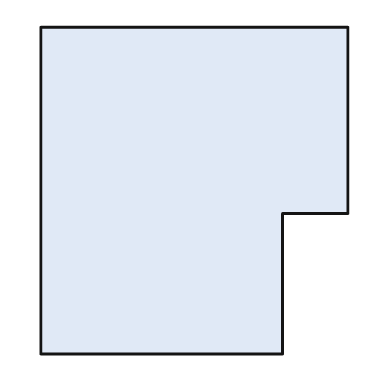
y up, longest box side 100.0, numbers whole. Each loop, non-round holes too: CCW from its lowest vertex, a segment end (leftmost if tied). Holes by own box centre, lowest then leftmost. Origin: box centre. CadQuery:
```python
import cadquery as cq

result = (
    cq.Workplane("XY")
    .moveTo(-47.0, -50.0)
    .lineTo(27.0, -50.0)
    .lineTo(27.0, -7.0)
    .lineTo(47.0, -7.0)
    .lineTo(47.0, 50.0)
    .lineTo(-47.0, 50.0)
    .close()
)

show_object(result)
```